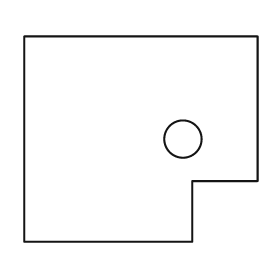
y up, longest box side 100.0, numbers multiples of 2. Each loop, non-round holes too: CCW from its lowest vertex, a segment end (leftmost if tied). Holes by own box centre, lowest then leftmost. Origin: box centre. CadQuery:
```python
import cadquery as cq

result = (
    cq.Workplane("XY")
    .moveTo(-50.0, -44.0)
    .lineTo(22.0, -44.0)
    .lineTo(22.0, -18.0)
    .lineTo(50.0, -18.0)
    .lineTo(50.0, 44.0)
    .lineTo(-50.0, 44.0)
    .close()
    .moveTo(18.0, 0.0)
    .circle(8.0)
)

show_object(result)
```